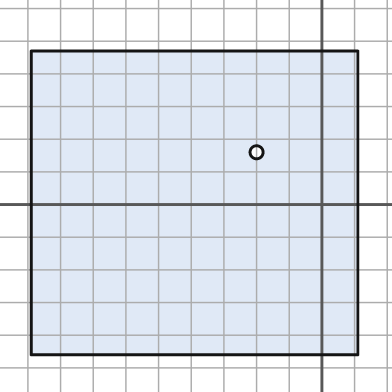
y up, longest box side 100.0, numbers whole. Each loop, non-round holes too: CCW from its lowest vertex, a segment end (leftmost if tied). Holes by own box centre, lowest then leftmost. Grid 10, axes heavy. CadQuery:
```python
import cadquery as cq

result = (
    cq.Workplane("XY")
    .moveTo(-89.0, -46.0)
    .lineTo(11.0, -46.0)
    .lineTo(11.0, 47.0)
    .lineTo(-89.0, 47.0)
    .close()
    .moveTo(-20.0, 16.0)
    .circle(2.0)
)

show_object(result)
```